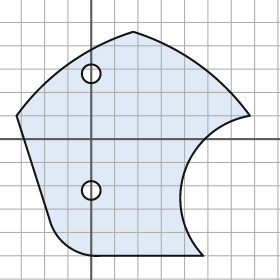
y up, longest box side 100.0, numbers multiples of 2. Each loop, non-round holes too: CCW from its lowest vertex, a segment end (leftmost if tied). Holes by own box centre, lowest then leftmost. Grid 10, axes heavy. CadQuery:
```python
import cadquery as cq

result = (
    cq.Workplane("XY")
    .moveTo(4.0, -50.0)
    .lineTo(48.0, -50.0)
    .threePointArc((40.0, -14.0), (68.0, 10.0))
    .threePointArc((46.0, 32.0), (18.0, 46.0))
    .threePointArc((-10.0, 32.0), (-32.0, 10.0))
    .lineTo(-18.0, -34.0)
    .threePointArc((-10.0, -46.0), (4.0, -50.0))
    .close()
    .moveTo(0.0, -22.0)
    .circle(4.0)
    .moveTo(0.0, 28.0)
    .circle(4.0)
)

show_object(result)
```